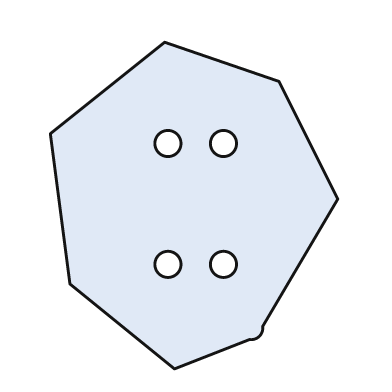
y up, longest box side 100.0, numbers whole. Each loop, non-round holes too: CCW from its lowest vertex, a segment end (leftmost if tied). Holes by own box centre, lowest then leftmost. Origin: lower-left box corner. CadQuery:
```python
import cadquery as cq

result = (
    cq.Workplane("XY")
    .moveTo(38.0, 0.0)
    .lineTo(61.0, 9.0)
    .threePointArc((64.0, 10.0), (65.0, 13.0))
    .lineTo(88.0, 52.0)
    .lineTo(70.0, 88.0)
    .lineTo(35.0, 100.0)
    .lineTo(0.0, 72.0)
    .lineTo(6.0, 26.0)
    .close()
    .moveTo(36.0, 32.0)
    .circle(4.0)
    .moveTo(53.0, 32.0)
    .circle(4.0)
    .moveTo(36.0, 69.0)
    .circle(4.0)
    .moveTo(53.0, 69.0)
    .circle(4.0)
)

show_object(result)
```